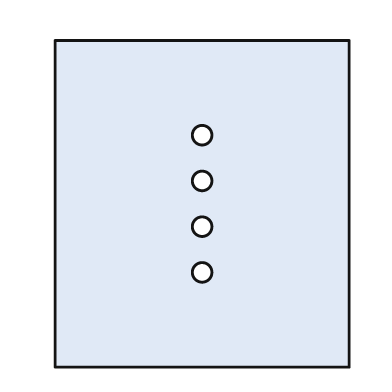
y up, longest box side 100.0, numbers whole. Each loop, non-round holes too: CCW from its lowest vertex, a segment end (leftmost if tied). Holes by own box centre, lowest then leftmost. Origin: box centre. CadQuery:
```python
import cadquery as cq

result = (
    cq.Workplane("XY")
    .moveTo(-45.0, -50.0)
    .lineTo(45.0, -50.0)
    .lineTo(45.0, 50.0)
    .lineTo(-45.0, 50.0)
    .close()
    .moveTo(0.0, -21.0)
    .circle(3.0)
    .moveTo(0.0, -7.0)
    .circle(3.0)
    .moveTo(0.0, 7.0)
    .circle(3.0)
    .moveTo(0.0, 21.0)
    .circle(3.0)
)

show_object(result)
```